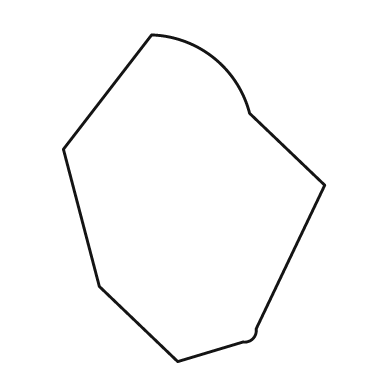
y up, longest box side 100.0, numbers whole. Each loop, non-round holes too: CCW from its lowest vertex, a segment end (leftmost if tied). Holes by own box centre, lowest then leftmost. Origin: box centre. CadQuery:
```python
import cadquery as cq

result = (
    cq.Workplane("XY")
    .moveTo(-5.0, -50.0)
    .lineTo(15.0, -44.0)
    .threePointArc((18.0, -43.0), (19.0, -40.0))
    .lineTo(40.0, 4.0)
    .lineTo(17.0, 26.0)
    .threePointArc((6.0, 43.0), (-13.0, 50.0))
    .lineTo(-40.0, 15.0)
    .lineTo(-29.0, -27.0)
    .close()
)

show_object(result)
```